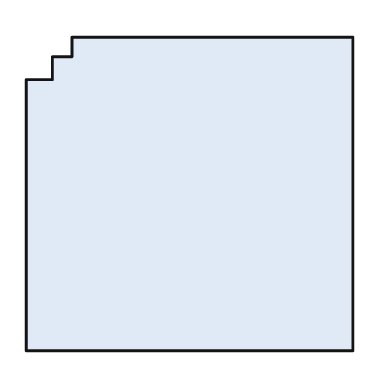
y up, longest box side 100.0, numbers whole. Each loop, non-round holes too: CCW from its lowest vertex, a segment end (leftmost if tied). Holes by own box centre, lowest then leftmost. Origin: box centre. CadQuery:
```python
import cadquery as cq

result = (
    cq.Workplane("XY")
    .moveTo(-50.0, -48.0)
    .lineTo(50.0, -48.0)
    .lineTo(50.0, 48.0)
    .lineTo(-36.0, 48.0)
    .lineTo(-36.0, 42.0)
    .lineTo(-42.0, 42.0)
    .lineTo(-42.0, 35.0)
    .lineTo(-50.0, 35.0)
    .close()
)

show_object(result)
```